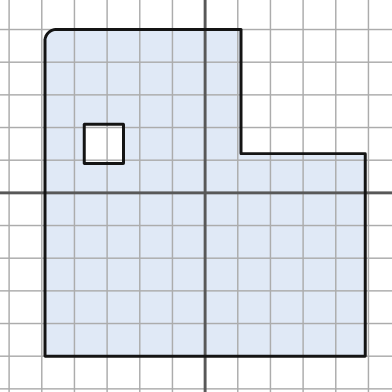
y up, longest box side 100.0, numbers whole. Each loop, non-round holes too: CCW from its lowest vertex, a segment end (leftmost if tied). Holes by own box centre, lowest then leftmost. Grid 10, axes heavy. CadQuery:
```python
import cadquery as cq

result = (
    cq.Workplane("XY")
    .moveTo(-49.0, -50.0)
    .lineTo(49.0, -50.0)
    .lineTo(49.0, 12.0)
    .lineTo(11.0, 12.0)
    .lineTo(11.0, 50.0)
    .lineTo(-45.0, 50.0)
    .threePointArc((-48.0, 49.0), (-49.0, 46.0))
    .close()
    .moveTo(-37.0, 9.0)
    .lineTo(-25.0, 9.0)
    .lineTo(-25.0, 21.0)
    .lineTo(-37.0, 21.0)
    .close()
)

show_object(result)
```